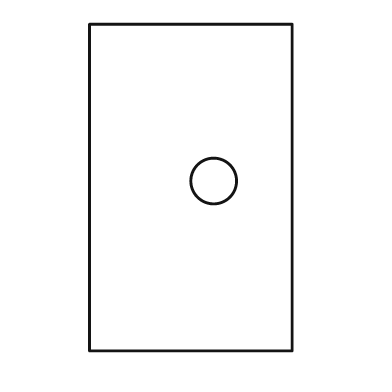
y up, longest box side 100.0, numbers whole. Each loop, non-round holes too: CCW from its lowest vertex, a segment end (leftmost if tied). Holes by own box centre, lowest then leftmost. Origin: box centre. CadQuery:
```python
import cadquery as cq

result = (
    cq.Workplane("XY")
    .moveTo(-31.0, -50.0)
    .lineTo(31.0, -50.0)
    .lineTo(31.0, 50.0)
    .lineTo(-31.0, 50.0)
    .close()
    .moveTo(7.0, 2.0)
    .circle(7.0)
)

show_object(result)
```